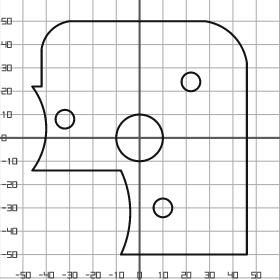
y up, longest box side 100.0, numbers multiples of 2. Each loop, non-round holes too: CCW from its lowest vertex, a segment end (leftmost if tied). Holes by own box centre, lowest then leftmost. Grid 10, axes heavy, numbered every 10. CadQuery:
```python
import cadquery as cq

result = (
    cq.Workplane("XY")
    .moveTo(-8.0, -50.0)
    .lineTo(46.0, -50.0)
    .lineTo(46.0, 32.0)
    .threePointArc((40.0, 44.0), (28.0, 50.0))
    .lineTo(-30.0, 50.0)
    .threePointArc((-38.0, 46.0), (-42.0, 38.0))
    .lineTo(-42.0, 22.0)
    .lineTo(-46.0, 22.0)
    .threePointArc((-40.0, 4.0), (-46.0, -14.0))
    .lineTo(-8.0, -14.0)
    .threePointArc((-4.0, -32.0), (-8.0, -50.0))
    .close()
    .moveTo(10.0, -30.0)
    .circle(4.0)
    .moveTo(0.0, 0.0)
    .circle(10.0)
    .moveTo(-32.0, 8.0)
    .circle(4.0)
    .moveTo(22.0, 24.0)
    .circle(4.0)
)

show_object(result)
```